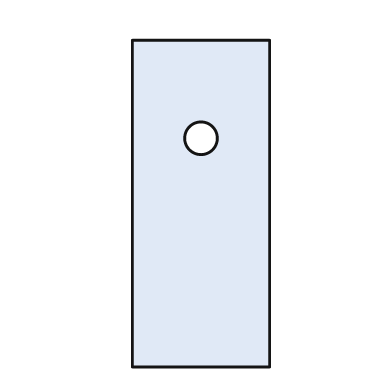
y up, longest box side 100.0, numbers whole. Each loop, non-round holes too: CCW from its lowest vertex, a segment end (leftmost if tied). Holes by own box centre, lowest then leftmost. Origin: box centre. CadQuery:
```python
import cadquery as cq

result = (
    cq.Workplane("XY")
    .moveTo(-21.0, -50.0)
    .lineTo(21.0, -50.0)
    .lineTo(21.0, 50.0)
    .lineTo(-21.0, 50.0)
    .close()
    .moveTo(0.0, 20.0)
    .circle(5.0)
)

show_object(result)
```